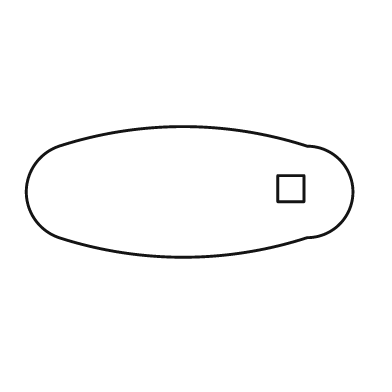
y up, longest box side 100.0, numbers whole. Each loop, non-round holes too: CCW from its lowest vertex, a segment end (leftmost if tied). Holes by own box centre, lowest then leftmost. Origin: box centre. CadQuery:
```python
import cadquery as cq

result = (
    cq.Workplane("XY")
    .moveTo(-40.0, -14.0)
    .threePointArc((-2.0, -20.0), (36.0, -14.0))
    .threePointArc((50.0, 0.0), (36.0, 14.0))
    .threePointArc((-2.0, 20.0), (-40.0, 14.0))
    .threePointArc((-50.0, 0.0), (-40.0, -14.0))
    .close()
    .moveTo(27.0, -3.0)
    .lineTo(35.0, -3.0)
    .lineTo(35.0, 5.0)
    .lineTo(27.0, 5.0)
    .close()
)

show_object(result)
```